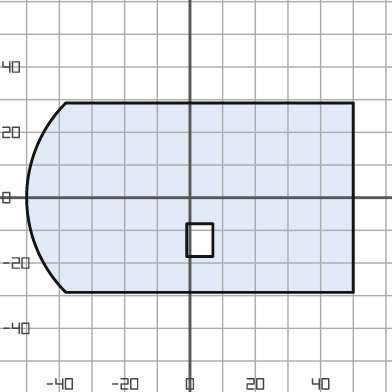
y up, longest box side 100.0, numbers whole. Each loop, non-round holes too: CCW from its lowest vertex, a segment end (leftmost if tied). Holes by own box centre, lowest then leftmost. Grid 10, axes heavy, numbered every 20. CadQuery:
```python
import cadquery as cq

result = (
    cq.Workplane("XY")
    .moveTo(-38.0, -29.0)
    .lineTo(50.0, -29.0)
    .lineTo(50.0, 29.0)
    .lineTo(-38.0, 29.0)
    .threePointArc((-50.0, 0.0), (-38.0, -29.0))
    .close()
    .moveTo(-1.0, -18.0)
    .lineTo(7.0, -18.0)
    .lineTo(7.0, -8.0)
    .lineTo(-1.0, -8.0)
    .close()
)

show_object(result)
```